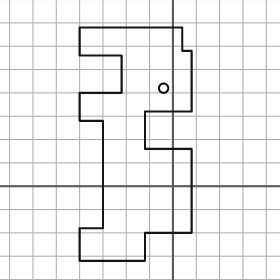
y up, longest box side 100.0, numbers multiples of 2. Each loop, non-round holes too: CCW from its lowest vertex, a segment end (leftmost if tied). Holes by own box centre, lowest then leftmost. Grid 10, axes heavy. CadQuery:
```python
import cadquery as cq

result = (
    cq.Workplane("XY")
    .moveTo(-40.0, -32.0)
    .lineTo(-12.0, -32.0)
    .lineTo(-12.0, -20.0)
    .lineTo(8.0, -20.0)
    .lineTo(8.0, 16.0)
    .lineTo(-12.0, 16.0)
    .lineTo(-12.0, 32.0)
    .lineTo(8.0, 32.0)
    .lineTo(8.0, 58.0)
    .lineTo(4.0, 58.0)
    .lineTo(4.0, 68.0)
    .lineTo(-40.0, 68.0)
    .lineTo(-40.0, 56.0)
    .lineTo(-22.0, 56.0)
    .lineTo(-22.0, 40.0)
    .lineTo(-40.0, 40.0)
    .lineTo(-40.0, 28.0)
    .lineTo(-30.0, 28.0)
    .lineTo(-30.0, -18.0)
    .lineTo(-40.0, -18.0)
    .close()
    .moveTo(-4.0, 42.0)
    .circle(2.0)
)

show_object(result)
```